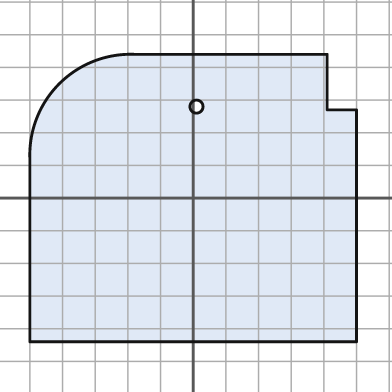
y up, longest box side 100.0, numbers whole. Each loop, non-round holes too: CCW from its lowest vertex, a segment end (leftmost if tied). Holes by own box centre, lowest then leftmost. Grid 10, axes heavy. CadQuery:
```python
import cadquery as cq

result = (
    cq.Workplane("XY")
    .moveTo(-50.0, -44.0)
    .lineTo(50.0, -44.0)
    .lineTo(50.0, 27.0)
    .lineTo(41.0, 27.0)
    .lineTo(41.0, 44.0)
    .lineTo(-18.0, 44.0)
    .threePointArc((-41.0, 35.0), (-50.0, 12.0))
    .close()
    .moveTo(1.0, 28.0)
    .circle(2.0)
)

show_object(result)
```